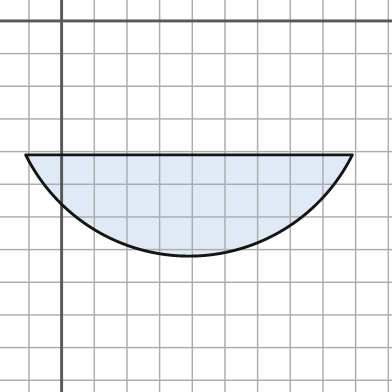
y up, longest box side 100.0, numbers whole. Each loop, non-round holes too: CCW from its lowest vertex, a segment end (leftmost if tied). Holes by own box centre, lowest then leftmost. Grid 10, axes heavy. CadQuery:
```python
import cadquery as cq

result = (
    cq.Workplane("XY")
    .moveTo(-11.0, -41.0)
    .threePointArc((39.0, -72.0), (89.0, -41.0))
    .close()
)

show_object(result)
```